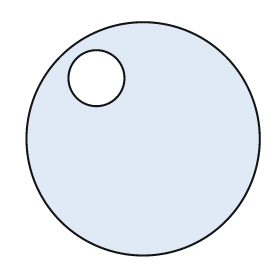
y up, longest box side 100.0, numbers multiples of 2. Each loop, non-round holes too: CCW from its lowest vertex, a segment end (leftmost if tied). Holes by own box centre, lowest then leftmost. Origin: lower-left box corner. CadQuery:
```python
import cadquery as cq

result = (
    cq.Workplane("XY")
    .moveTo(50.0, 50.0)
    .circle(50.0)
    .moveTo(30.0, 76.0)
    .circle(12.0)
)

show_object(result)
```